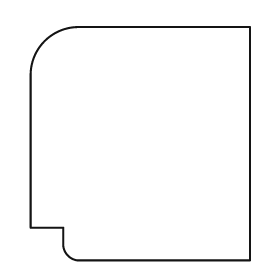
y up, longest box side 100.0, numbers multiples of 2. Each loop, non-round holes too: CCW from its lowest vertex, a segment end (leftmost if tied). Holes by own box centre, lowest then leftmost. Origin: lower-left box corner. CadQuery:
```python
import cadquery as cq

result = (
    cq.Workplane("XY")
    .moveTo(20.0, 0.0)
    .lineTo(94.0, 0.0)
    .lineTo(94.0, 100.0)
    .lineTo(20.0, 100.0)
    .threePointArc((6.0, 94.0), (0.0, 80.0))
    .lineTo(0.0, 14.0)
    .lineTo(14.0, 14.0)
    .lineTo(14.0, 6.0)
    .threePointArc((16.0, 2.0), (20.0, 0.0))
    .close()
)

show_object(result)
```